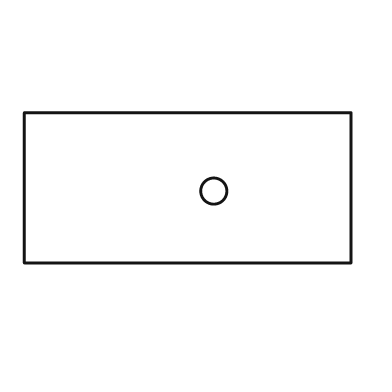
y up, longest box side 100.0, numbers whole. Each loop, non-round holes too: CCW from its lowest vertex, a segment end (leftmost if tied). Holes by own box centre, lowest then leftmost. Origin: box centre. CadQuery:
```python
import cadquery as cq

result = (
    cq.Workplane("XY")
    .moveTo(-50.0, -23.0)
    .lineTo(50.0, -23.0)
    .lineTo(50.0, 23.0)
    .lineTo(-50.0, 23.0)
    .close()
    .moveTo(8.0, -1.0)
    .circle(4.0)
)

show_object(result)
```